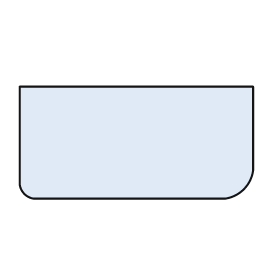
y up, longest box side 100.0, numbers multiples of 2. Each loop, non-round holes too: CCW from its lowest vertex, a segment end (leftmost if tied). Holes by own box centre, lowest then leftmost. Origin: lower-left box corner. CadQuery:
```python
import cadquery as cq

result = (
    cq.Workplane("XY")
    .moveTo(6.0, 0.0)
    .lineTo(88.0, 0.0)
    .threePointArc((96.0, 4.0), (100.0, 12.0))
    .lineTo(100.0, 48.0)
    .lineTo(0.0, 48.0)
    .lineTo(0.0, 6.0)
    .threePointArc((2.0, 2.0), (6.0, 0.0))
    .close()
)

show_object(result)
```